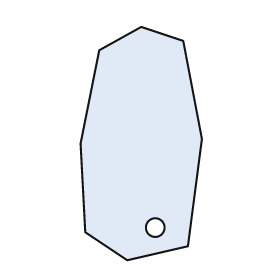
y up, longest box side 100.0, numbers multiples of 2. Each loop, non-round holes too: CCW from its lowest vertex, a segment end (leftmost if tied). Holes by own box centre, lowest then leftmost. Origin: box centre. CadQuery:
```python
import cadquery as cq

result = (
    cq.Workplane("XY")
    .moveTo(-6.0, -50.0)
    .lineTo(20.0, -44.0)
    .lineTo(26.0, 2.0)
    .lineTo(18.0, 44.0)
    .lineTo(0.0, 50.0)
    .lineTo(-18.0, 40.0)
    .lineTo(-26.0, 0.0)
    .lineTo(-24.0, -38.0)
    .close()
    .moveTo(6.0, -36.0)
    .circle(4.0)
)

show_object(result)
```